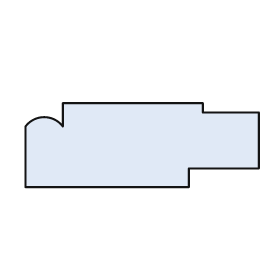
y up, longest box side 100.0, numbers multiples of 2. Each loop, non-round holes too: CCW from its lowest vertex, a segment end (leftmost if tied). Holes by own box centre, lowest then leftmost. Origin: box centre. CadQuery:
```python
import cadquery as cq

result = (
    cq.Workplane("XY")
    .moveTo(-50.0, -18.0)
    .lineTo(20.0, -18.0)
    .lineTo(20.0, -10.0)
    .lineTo(50.0, -10.0)
    .lineTo(50.0, 14.0)
    .lineTo(26.0, 14.0)
    .lineTo(26.0, 18.0)
    .lineTo(-34.0, 18.0)
    .lineTo(-34.0, 8.0)
    .threePointArc((-42.0, 12.0), (-50.0, 8.0))
    .close()
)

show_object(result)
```